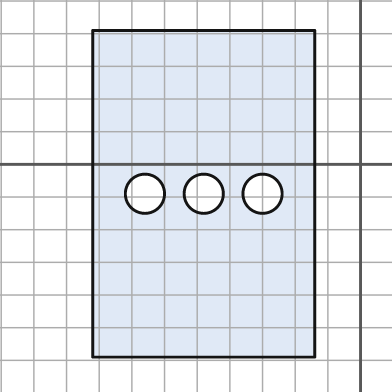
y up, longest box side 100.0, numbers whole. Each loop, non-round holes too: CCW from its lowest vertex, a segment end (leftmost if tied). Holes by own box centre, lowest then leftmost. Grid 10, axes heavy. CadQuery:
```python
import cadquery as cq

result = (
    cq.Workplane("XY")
    .moveTo(-82.0, -59.0)
    .lineTo(-14.0, -59.0)
    .lineTo(-14.0, 41.0)
    .lineTo(-82.0, 41.0)
    .close()
    .moveTo(-66.0, -9.0)
    .circle(6.0)
    .moveTo(-48.0, -9.0)
    .circle(6.0)
    .moveTo(-30.0, -9.0)
    .circle(6.0)
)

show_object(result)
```